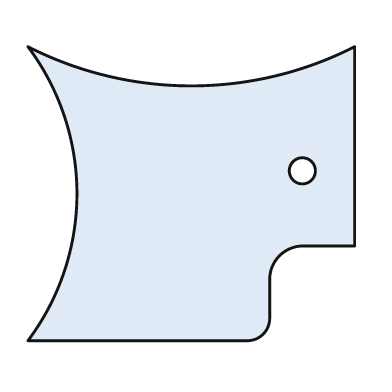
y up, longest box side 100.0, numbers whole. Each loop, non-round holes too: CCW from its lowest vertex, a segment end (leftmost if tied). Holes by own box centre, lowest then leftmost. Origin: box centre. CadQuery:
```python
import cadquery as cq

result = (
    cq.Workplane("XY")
    .moveTo(-50.0, -45.0)
    .lineTo(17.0, -45.0)
    .threePointArc((22.0, -43.0), (24.0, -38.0))
    .lineTo(24.0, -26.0)
    .threePointArc((27.0, -19.0), (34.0, -16.0))
    .lineTo(50.0, -16.0)
    .lineTo(50.0, 45.0)
    .threePointArc((0.0, 33.0), (-50.0, 45.0))
    .threePointArc((-35.0, 0.0), (-50.0, -45.0))
    .close()
    .moveTo(34.0, 7.0)
    .circle(4.0)
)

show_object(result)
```